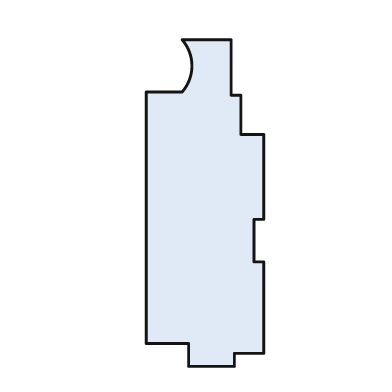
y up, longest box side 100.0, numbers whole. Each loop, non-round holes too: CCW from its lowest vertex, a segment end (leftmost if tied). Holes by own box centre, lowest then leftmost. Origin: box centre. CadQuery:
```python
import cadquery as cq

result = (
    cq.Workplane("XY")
    .moveTo(-5.0, -50.0)
    .lineTo(9.0, -50.0)
    .lineTo(9.0, -46.0)
    .lineTo(18.0, -46.0)
    .lineTo(18.0, -18.0)
    .lineTo(15.0, -18.0)
    .lineTo(15.0, -5.0)
    .lineTo(18.0, -5.0)
    .lineTo(18.0, 21.0)
    .lineTo(11.0, 21.0)
    .lineTo(11.0, 33.0)
    .lineTo(8.0, 33.0)
    .lineTo(8.0, 50.0)
    .lineTo(-7.0, 50.0)
    .threePointArc((-4.0, 42.0), (-7.0, 34.0))
    .lineTo(-18.0, 34.0)
    .lineTo(-18.0, -43.0)
    .lineTo(-5.0, -43.0)
    .close()
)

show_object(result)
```